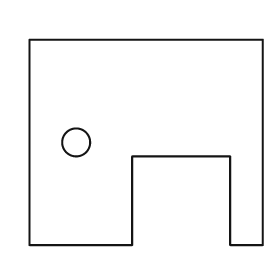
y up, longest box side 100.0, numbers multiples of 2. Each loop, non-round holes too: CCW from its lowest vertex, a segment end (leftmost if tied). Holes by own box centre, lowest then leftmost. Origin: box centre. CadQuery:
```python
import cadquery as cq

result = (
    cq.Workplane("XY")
    .moveTo(-50.0, -44.0)
    .lineTo(-6.0, -44.0)
    .lineTo(-6.0, -6.0)
    .lineTo(36.0, -6.0)
    .lineTo(36.0, -44.0)
    .lineTo(50.0, -44.0)
    .lineTo(50.0, 44.0)
    .lineTo(-50.0, 44.0)
    .close()
    .moveTo(-30.0, 0.0)
    .circle(6.0)
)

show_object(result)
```